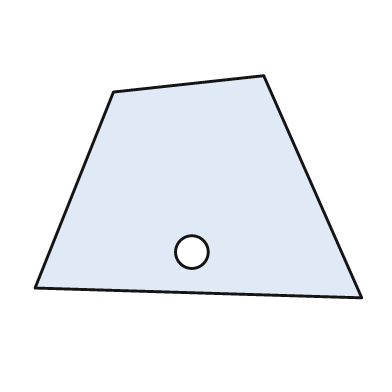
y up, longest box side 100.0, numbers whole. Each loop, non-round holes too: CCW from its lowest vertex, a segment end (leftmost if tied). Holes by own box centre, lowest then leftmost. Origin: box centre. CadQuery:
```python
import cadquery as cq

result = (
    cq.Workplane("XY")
    .moveTo(50.0, -34.0)
    .lineTo(20.0, 34.0)
    .lineTo(-26.0, 29.0)
    .lineTo(-50.0, -31.0)
    .close()
    .moveTo(-2.0, -20.0)
    .circle(5.0)
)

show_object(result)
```